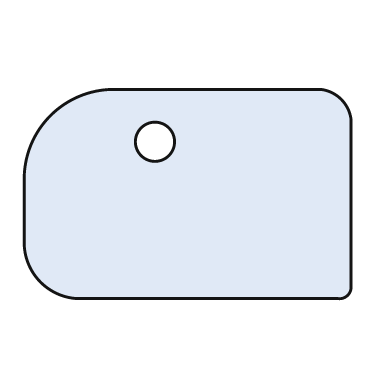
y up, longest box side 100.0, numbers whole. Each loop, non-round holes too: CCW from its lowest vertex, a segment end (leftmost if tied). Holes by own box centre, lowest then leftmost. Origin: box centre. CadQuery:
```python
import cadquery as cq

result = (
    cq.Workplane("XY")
    .moveTo(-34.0, -32.0)
    .lineTo(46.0, -32.0)
    .threePointArc((49.0, -31.0), (50.0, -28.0))
    .lineTo(50.0, 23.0)
    .threePointArc((47.0, 29.0), (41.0, 32.0))
    .lineTo(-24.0, 32.0)
    .threePointArc((-42.0, 24.0), (-50.0, 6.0))
    .lineTo(-50.0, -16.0)
    .threePointArc((-45.0, -27.0), (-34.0, -32.0))
    .close()
    .moveTo(-10.0, 16.0)
    .circle(6.0)
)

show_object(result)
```